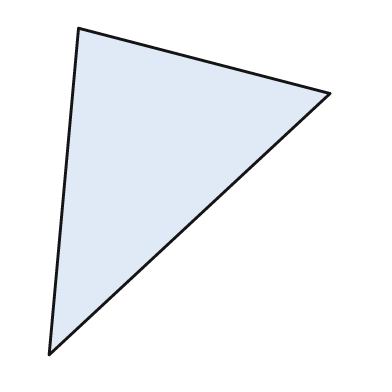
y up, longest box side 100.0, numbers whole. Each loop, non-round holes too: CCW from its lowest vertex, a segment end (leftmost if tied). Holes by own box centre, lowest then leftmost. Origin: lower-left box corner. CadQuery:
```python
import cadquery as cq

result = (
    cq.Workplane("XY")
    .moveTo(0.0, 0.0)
    .lineTo(86.0, 80.0)
    .lineTo(9.0, 100.0)
    .close()
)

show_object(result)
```